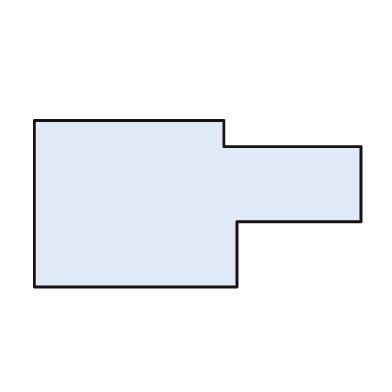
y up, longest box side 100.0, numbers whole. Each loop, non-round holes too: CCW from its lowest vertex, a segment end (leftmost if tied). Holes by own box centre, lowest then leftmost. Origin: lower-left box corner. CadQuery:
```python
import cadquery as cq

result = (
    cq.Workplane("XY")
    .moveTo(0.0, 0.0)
    .lineTo(62.0, 0.0)
    .lineTo(62.0, 20.0)
    .lineTo(100.0, 20.0)
    .lineTo(100.0, 43.0)
    .lineTo(58.0, 43.0)
    .lineTo(58.0, 51.0)
    .lineTo(0.0, 51.0)
    .close()
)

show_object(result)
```